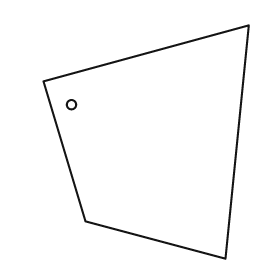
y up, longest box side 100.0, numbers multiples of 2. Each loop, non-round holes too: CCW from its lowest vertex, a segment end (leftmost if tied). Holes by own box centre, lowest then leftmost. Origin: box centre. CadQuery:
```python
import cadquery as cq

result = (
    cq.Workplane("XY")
    .moveTo(34.0, -50.0)
    .lineTo(44.0, 50.0)
    .lineTo(-44.0, 26.0)
    .lineTo(-26.0, -34.0)
    .close()
    .moveTo(-32.0, 16.0)
    .circle(2.0)
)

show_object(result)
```